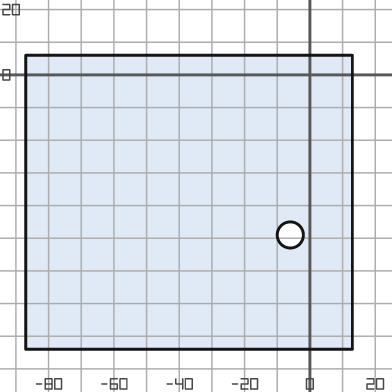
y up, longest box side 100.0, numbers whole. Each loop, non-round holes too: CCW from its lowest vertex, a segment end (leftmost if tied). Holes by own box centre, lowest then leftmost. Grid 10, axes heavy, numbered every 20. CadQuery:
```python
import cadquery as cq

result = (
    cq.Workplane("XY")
    .moveTo(-87.0, -84.0)
    .lineTo(13.0, -84.0)
    .lineTo(13.0, 6.0)
    .lineTo(-87.0, 6.0)
    .close()
    .moveTo(-6.0, -49.0)
    .circle(4.0)
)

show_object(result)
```